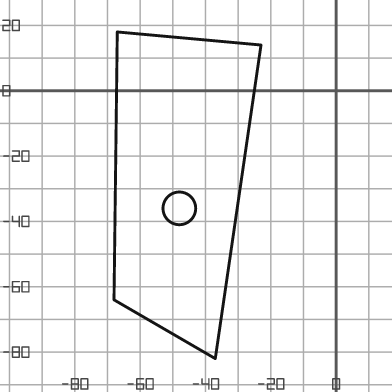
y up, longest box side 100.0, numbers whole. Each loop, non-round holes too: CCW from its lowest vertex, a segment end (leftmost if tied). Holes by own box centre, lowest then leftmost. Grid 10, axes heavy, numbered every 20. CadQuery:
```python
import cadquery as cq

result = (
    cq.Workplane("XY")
    .moveTo(-37.0, -82.0)
    .lineTo(-23.0, 14.0)
    .lineTo(-67.0, 18.0)
    .lineTo(-68.0, -64.0)
    .close()
    .moveTo(-48.0, -36.0)
    .circle(5.0)
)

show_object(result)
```